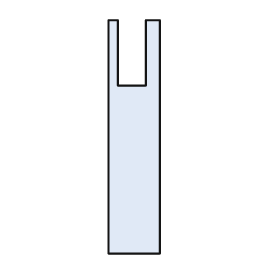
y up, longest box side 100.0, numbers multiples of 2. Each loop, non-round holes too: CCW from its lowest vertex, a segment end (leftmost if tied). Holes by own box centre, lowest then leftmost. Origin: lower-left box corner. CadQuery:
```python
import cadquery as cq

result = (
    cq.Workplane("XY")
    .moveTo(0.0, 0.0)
    .lineTo(22.0, 0.0)
    .lineTo(22.0, 100.0)
    .lineTo(16.0, 100.0)
    .lineTo(16.0, 72.0)
    .lineTo(4.0, 72.0)
    .lineTo(4.0, 100.0)
    .lineTo(0.0, 100.0)
    .close()
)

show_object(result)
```